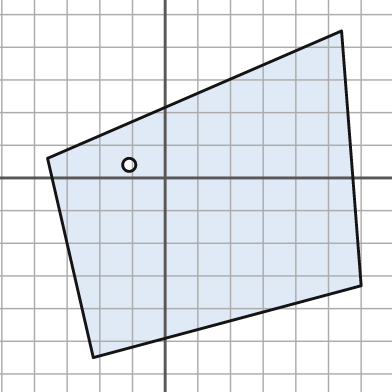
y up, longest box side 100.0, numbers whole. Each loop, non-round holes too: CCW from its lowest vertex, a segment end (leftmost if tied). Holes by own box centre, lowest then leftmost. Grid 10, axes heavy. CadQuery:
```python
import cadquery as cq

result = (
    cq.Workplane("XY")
    .moveTo(-22.0, -55.0)
    .lineTo(60.0, -33.0)
    .lineTo(54.0, 45.0)
    .lineTo(-36.0, 6.0)
    .close()
    .moveTo(-11.0, 4.0)
    .circle(2.0)
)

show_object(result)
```